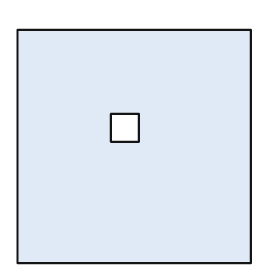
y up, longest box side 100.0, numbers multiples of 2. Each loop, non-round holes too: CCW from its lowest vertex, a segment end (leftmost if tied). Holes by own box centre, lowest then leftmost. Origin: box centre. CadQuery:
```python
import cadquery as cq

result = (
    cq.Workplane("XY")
    .moveTo(-50.0, -50.0)
    .lineTo(50.0, -50.0)
    .lineTo(50.0, 50.0)
    .lineTo(-50.0, 50.0)
    .close()
    .moveTo(-10.0, 2.0)
    .lineTo(2.0, 2.0)
    .lineTo(2.0, 14.0)
    .lineTo(-10.0, 14.0)
    .close()
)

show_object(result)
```